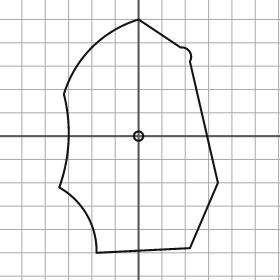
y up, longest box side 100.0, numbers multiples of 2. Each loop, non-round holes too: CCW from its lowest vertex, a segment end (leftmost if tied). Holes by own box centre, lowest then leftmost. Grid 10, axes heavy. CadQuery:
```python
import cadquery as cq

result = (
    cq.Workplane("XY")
    .moveTo(-18.0, -50.0)
    .lineTo(22.0, -48.0)
    .lineTo(34.0, -20.0)
    .lineTo(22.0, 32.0)
    .threePointArc((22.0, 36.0), (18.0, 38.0))
    .lineTo(0.0, 50.0)
    .threePointArc((-20.0, 38.0), (-32.0, 18.0))
    .threePointArc((-30.0, -2.0), (-34.0, -22.0))
    .threePointArc((-22.0, -34.0), (-18.0, -50.0))
    .close()
    .moveTo(0.0, 0.0)
    .circle(2.0)
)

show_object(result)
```